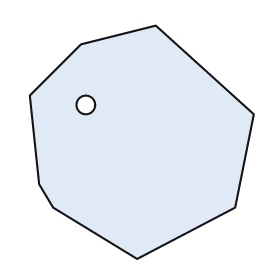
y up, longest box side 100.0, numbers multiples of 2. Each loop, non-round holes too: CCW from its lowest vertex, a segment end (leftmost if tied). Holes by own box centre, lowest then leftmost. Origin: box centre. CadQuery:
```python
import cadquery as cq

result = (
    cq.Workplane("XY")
    .moveTo(-2.0, -50.0)
    .lineTo(40.0, -28.0)
    .lineTo(48.0, 12.0)
    .lineTo(6.0, 50.0)
    .lineTo(-26.0, 42.0)
    .lineTo(-48.0, 20.0)
    .lineTo(-44.0, -18.0)
    .lineTo(-38.0, -28.0)
    .close()
    .moveTo(-24.0, 16.0)
    .circle(4.0)
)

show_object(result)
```